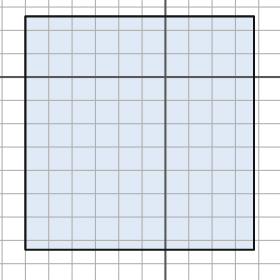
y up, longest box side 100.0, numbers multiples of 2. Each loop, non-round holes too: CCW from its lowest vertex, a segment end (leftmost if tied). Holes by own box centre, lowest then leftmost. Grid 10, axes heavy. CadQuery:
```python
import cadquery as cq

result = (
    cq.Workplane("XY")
    .moveTo(-60.0, -74.0)
    .lineTo(38.0, -74.0)
    .lineTo(38.0, 26.0)
    .lineTo(-60.0, 26.0)
    .close()
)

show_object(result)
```